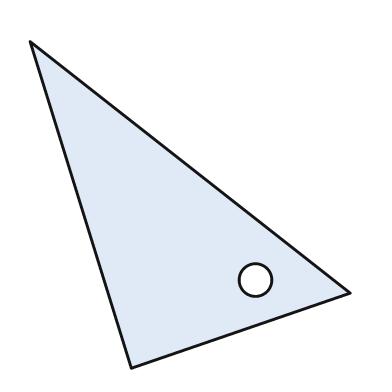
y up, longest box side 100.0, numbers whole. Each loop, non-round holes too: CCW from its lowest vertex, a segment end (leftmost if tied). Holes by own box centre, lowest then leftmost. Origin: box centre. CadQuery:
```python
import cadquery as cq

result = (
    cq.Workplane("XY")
    .moveTo(-18.0, -50.0)
    .lineTo(49.0, -27.0)
    .lineTo(-49.0, 50.0)
    .close()
    .moveTo(20.0, -23.0)
    .circle(5.0)
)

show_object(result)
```